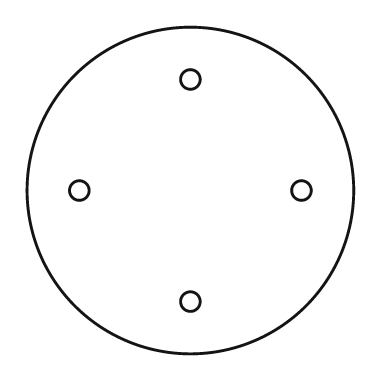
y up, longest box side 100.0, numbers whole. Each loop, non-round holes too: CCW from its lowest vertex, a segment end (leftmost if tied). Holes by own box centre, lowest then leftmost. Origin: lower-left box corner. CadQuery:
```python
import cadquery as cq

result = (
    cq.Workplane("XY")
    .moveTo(50.0, 50.0)
    .circle(50.0)
    .moveTo(50.0, 16.0)
    .circle(3.0)
    .moveTo(16.0, 50.0)
    .circle(3.0)
    .moveTo(84.0, 50.0)
    .circle(3.0)
    .moveTo(50.0, 84.0)
    .circle(3.0)
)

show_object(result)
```